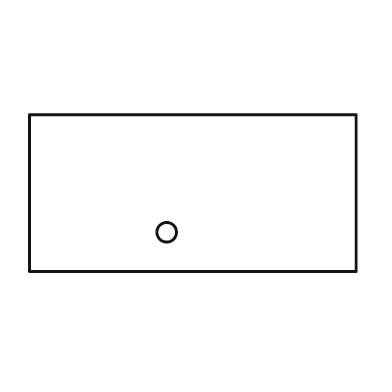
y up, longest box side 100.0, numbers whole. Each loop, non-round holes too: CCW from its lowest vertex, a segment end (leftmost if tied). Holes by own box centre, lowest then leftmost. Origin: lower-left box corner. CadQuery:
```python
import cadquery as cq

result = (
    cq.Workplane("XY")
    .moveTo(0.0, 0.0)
    .lineTo(100.0, 0.0)
    .lineTo(100.0, 48.0)
    .lineTo(0.0, 48.0)
    .close()
    .moveTo(42.0, 12.0)
    .circle(3.0)
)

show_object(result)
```